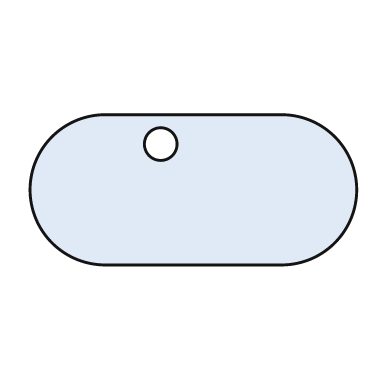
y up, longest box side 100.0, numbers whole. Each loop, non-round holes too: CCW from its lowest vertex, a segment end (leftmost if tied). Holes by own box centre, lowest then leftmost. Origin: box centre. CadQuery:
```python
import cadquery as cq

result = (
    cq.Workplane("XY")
    .moveTo(-27.0, -23.0)
    .lineTo(27.0, -23.0)
    .threePointArc((50.0, 0.0), (27.0, 23.0))
    .lineTo(-27.0, 23.0)
    .threePointArc((-50.0, 0.0), (-27.0, -23.0))
    .close()
    .moveTo(-10.0, 14.0)
    .circle(5.0)
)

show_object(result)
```